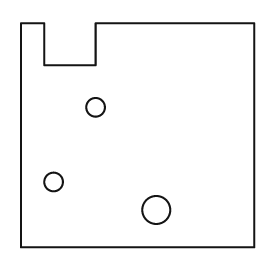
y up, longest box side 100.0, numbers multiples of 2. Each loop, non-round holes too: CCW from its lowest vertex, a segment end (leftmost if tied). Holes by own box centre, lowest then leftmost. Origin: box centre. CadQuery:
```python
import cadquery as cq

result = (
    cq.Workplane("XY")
    .moveTo(-50.0, -48.0)
    .lineTo(50.0, -48.0)
    .lineTo(50.0, 48.0)
    .lineTo(-18.0, 48.0)
    .lineTo(-18.0, 30.0)
    .lineTo(-40.0, 30.0)
    .lineTo(-40.0, 48.0)
    .lineTo(-50.0, 48.0)
    .close()
    .moveTo(8.0, -32.0)
    .circle(6.0)
    .moveTo(-36.0, -20.0)
    .circle(4.0)
    .moveTo(-18.0, 12.0)
    .circle(4.0)
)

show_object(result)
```